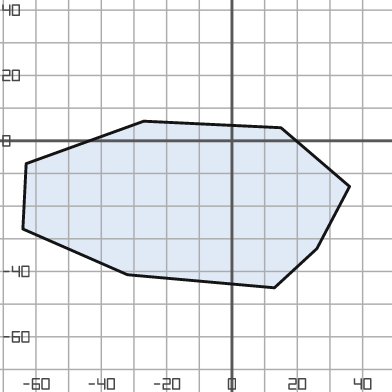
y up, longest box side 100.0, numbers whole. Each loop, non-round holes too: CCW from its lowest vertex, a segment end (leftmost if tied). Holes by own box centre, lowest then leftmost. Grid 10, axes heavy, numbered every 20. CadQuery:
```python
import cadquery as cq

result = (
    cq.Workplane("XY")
    .moveTo(13.0, -45.0)
    .lineTo(26.0, -33.0)
    .lineTo(36.0, -14.0)
    .lineTo(15.0, 4.0)
    .lineTo(-27.0, 6.0)
    .lineTo(-63.0, -7.0)
    .lineTo(-64.0, -27.0)
    .lineTo(-32.0, -41.0)
    .close()
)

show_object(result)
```